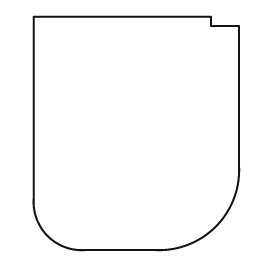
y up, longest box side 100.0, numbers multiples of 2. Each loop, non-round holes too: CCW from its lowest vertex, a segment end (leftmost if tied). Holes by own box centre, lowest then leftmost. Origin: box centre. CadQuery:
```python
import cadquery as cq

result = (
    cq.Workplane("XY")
    .moveTo(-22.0, -50.0)
    .lineTo(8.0, -50.0)
    .threePointArc((34.0, -40.0), (44.0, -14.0))
    .lineTo(44.0, 46.0)
    .lineTo(32.0, 46.0)
    .lineTo(32.0, 50.0)
    .lineTo(-44.0, 50.0)
    .lineTo(-44.0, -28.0)
    .threePointArc((-38.0, -44.0), (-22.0, -50.0))
    .close()
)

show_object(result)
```